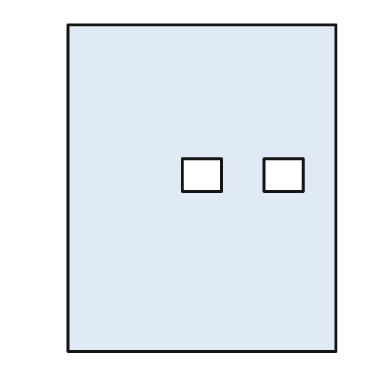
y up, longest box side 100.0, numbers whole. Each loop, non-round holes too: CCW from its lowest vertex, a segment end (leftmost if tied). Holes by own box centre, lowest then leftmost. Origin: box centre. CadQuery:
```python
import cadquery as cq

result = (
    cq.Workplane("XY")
    .moveTo(-41.0, -50.0)
    .lineTo(41.0, -50.0)
    .lineTo(41.0, 50.0)
    .lineTo(-41.0, 50.0)
    .close()
    .moveTo(-6.0, -1.0)
    .lineTo(6.0, -1.0)
    .lineTo(6.0, 9.0)
    .lineTo(-6.0, 9.0)
    .close()
    .moveTo(19.0, -1.0)
    .lineTo(31.0, -1.0)
    .lineTo(31.0, 9.0)
    .lineTo(19.0, 9.0)
    .close()
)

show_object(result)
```